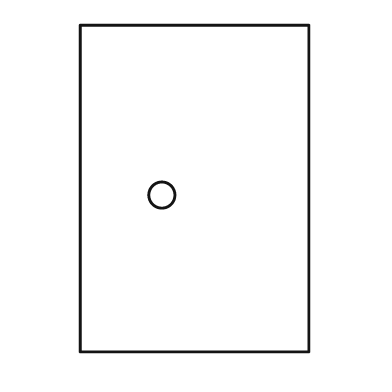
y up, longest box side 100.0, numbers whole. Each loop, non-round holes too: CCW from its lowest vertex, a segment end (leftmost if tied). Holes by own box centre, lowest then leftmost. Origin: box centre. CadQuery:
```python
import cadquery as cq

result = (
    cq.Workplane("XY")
    .moveTo(-35.0, -50.0)
    .lineTo(35.0, -50.0)
    .lineTo(35.0, 50.0)
    .lineTo(-35.0, 50.0)
    .close()
    .moveTo(-10.0, -2.0)
    .circle(4.0)
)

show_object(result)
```